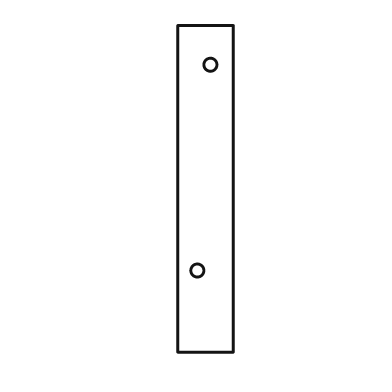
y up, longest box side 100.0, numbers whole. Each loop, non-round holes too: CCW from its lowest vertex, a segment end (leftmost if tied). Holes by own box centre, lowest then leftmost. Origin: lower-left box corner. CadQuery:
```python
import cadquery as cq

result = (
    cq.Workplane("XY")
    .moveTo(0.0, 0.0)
    .lineTo(17.0, 0.0)
    .lineTo(17.0, 100.0)
    .lineTo(0.0, 100.0)
    .close()
    .moveTo(6.0, 25.0)
    .circle(2.0)
    .moveTo(10.0, 88.0)
    .circle(2.0)
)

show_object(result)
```